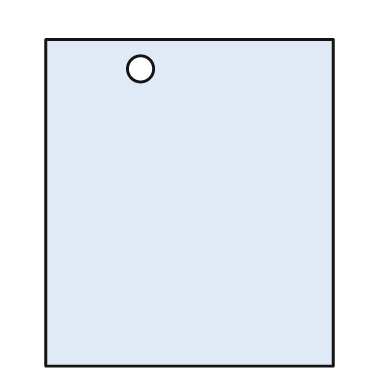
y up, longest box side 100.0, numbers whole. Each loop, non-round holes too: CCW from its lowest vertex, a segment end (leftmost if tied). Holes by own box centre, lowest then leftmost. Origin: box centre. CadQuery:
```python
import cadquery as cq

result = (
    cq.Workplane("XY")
    .moveTo(-44.0, -50.0)
    .lineTo(44.0, -50.0)
    .lineTo(44.0, 50.0)
    .lineTo(-44.0, 50.0)
    .close()
    .moveTo(-15.0, 41.0)
    .circle(4.0)
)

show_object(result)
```